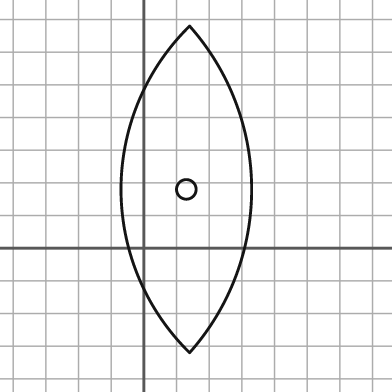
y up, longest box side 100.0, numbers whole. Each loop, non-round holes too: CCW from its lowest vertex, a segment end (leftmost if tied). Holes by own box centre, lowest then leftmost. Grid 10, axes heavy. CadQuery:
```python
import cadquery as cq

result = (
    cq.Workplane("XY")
    .moveTo(14.0, -32.0)
    .threePointArc((33.0, 18.0), (14.0, 68.0))
    .threePointArc((-7.0, 18.0), (14.0, -32.0))
    .close()
    .moveTo(13.0, 18.0)
    .circle(3.0)
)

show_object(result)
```